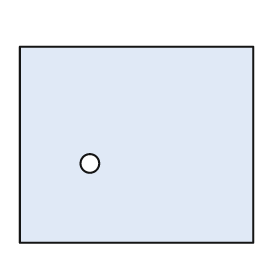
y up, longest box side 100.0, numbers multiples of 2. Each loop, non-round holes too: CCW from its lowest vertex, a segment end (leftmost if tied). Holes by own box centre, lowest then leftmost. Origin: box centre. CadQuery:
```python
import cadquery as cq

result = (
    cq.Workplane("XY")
    .moveTo(-50.0, -42.0)
    .lineTo(50.0, -42.0)
    .lineTo(50.0, 42.0)
    .lineTo(-50.0, 42.0)
    .close()
    .moveTo(-20.0, -8.0)
    .circle(4.0)
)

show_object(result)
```